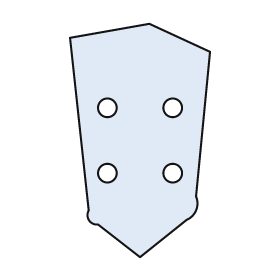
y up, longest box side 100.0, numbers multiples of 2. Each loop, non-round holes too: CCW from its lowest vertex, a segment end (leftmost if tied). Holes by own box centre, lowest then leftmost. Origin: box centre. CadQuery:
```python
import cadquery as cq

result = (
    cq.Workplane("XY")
    .moveTo(0.0, -50.0)
    .lineTo(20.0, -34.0)
    .threePointArc((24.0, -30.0), (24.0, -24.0))
    .lineTo(30.0, 38.0)
    .lineTo(4.0, 50.0)
    .lineTo(-30.0, 44.0)
    .lineTo(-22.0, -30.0)
    .threePointArc((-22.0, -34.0), (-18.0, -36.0))
    .close()
    .moveTo(-14.0, -14.0)
    .circle(4.0)
    .moveTo(14.0, -14.0)
    .circle(4.0)
    .moveTo(-14.0, 14.0)
    .circle(4.0)
    .moveTo(14.0, 14.0)
    .circle(4.0)
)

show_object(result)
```